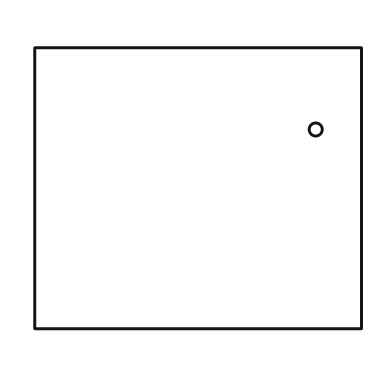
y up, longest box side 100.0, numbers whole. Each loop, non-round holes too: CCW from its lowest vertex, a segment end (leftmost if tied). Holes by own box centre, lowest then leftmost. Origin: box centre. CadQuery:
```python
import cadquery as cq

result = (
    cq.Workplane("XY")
    .moveTo(-50.0, -43.0)
    .lineTo(50.0, -43.0)
    .lineTo(50.0, 43.0)
    .lineTo(-50.0, 43.0)
    .close()
    .moveTo(36.0, 18.0)
    .circle(2.0)
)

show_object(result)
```